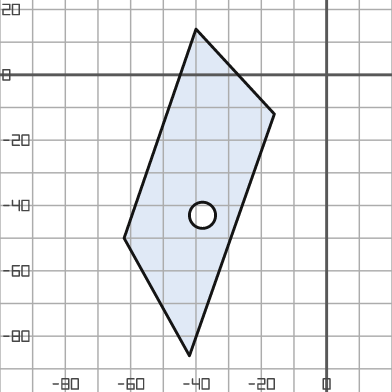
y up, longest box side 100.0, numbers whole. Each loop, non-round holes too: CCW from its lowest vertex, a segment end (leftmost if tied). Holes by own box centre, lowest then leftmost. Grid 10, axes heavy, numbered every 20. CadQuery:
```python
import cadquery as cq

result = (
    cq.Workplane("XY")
    .moveTo(-42.0, -86.0)
    .lineTo(-16.0, -12.0)
    .lineTo(-40.0, 14.0)
    .lineTo(-62.0, -50.0)
    .close()
    .moveTo(-38.0, -43.0)
    .circle(4.0)
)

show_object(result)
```